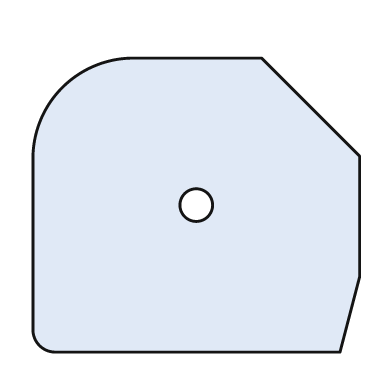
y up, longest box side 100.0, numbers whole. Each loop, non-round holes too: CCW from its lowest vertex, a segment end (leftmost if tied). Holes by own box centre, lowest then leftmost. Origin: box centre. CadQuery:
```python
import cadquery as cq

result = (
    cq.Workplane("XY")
    .moveTo(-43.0, -45.0)
    .lineTo(44.0, -45.0)
    .lineTo(50.0, -22.0)
    .lineTo(50.0, 15.0)
    .lineTo(20.0, 45.0)
    .lineTo(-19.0, 45.0)
    .threePointArc((-41.0, 36.0), (-50.0, 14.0))
    .lineTo(-50.0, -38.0)
    .threePointArc((-48.0, -43.0), (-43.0, -45.0))
    .close()
    .moveTo(0.0, 0.0)
    .circle(5.0)
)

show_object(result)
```